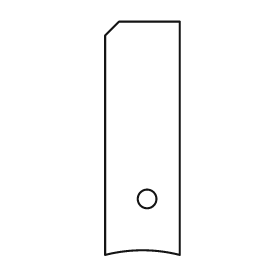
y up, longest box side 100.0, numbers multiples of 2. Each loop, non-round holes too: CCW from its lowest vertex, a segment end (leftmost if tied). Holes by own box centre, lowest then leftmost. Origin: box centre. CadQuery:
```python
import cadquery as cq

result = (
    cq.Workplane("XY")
    .moveTo(-16.0, -50.0)
    .threePointArc((0.0, -48.0), (16.0, -50.0))
    .lineTo(16.0, 50.0)
    .lineTo(-10.0, 50.0)
    .lineTo(-16.0, 44.0)
    .close()
    .moveTo(2.0, -26.0)
    .circle(4.0)
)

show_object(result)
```